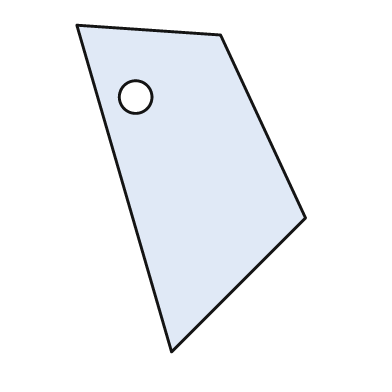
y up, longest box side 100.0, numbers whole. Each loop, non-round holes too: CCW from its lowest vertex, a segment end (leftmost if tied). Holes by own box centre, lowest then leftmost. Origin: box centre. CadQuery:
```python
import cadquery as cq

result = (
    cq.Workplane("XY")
    .moveTo(-6.0, -50.0)
    .lineTo(35.0, -9.0)
    .lineTo(9.0, 47.0)
    .lineTo(-35.0, 50.0)
    .close()
    .moveTo(-17.0, 28.0)
    .circle(5.0)
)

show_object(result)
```